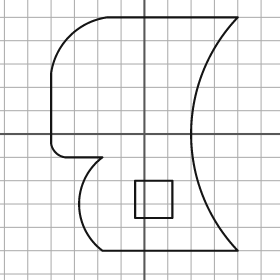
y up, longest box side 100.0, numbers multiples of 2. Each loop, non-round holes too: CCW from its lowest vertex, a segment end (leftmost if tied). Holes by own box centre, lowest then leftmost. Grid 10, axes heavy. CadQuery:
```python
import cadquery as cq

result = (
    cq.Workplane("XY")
    .moveTo(-18.0, -50.0)
    .lineTo(40.0, -50.0)
    .threePointArc((20.0, 0.0), (40.0, 50.0))
    .lineTo(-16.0, 50.0)
    .threePointArc((-32.0, 42.0), (-40.0, 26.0))
    .lineTo(-40.0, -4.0)
    .threePointArc((-38.0, -8.0), (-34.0, -10.0))
    .lineTo(-18.0, -10.0)
    .threePointArc((-28.0, -30.0), (-18.0, -50.0))
    .close()
    .moveTo(-4.0, -36.0)
    .lineTo(12.0, -36.0)
    .lineTo(12.0, -20.0)
    .lineTo(-4.0, -20.0)
    .close()
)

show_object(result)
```